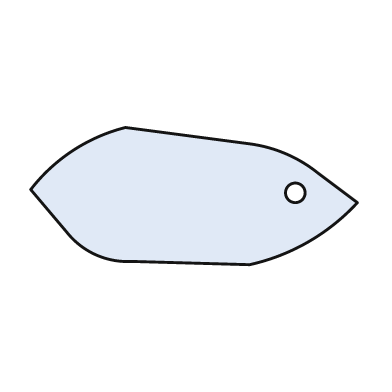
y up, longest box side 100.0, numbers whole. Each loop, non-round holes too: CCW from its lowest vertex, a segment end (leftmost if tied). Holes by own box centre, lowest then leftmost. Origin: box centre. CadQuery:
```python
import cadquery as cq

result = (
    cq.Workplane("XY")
    .moveTo(17.0, -21.0)
    .threePointArc((35.0, -14.0), (50.0, -2.0))
    .lineTo(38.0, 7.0)
    .threePointArc((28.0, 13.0), (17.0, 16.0))
    .lineTo(-21.0, 21.0)
    .threePointArc((-37.0, 14.0), (-50.0, 2.0))
    .lineTo(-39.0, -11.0)
    .threePointArc((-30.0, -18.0), (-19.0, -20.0))
    .close()
    .moveTo(31.0, 1.0)
    .circle(3.0)
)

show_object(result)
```